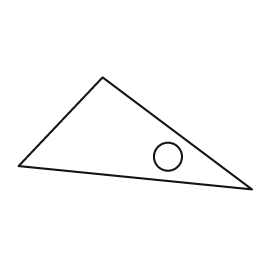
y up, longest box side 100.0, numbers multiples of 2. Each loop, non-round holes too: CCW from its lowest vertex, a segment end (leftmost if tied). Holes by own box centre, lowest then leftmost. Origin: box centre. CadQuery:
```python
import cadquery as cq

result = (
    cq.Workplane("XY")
    .moveTo(50.0, -24.0)
    .lineTo(-14.0, 24.0)
    .lineTo(-50.0, -14.0)
    .close()
    .moveTo(14.0, -10.0)
    .circle(6.0)
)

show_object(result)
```